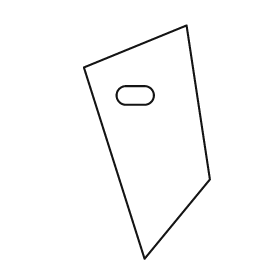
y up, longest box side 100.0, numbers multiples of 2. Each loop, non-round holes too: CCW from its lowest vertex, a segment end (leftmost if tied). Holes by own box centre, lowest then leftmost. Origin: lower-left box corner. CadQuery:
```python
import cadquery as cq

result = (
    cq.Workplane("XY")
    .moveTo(26.0, 0.0)
    .lineTo(54.0, 34.0)
    .lineTo(44.0, 100.0)
    .lineTo(0.0, 82.0)
    .close()
    .moveTo(18.0, 66.0)
    .lineTo(26.0, 66.0)
    .threePointArc((30.0, 70.0), (26.0, 74.0))
    .lineTo(18.0, 74.0)
    .threePointArc((14.0, 70.0), (18.0, 66.0))
    .close()
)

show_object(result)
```